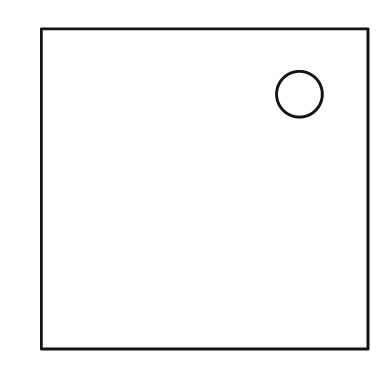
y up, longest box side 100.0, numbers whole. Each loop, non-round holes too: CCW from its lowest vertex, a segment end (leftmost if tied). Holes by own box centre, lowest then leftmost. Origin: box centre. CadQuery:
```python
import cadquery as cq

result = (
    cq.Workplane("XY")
    .moveTo(-50.0, -49.0)
    .lineTo(50.0, -49.0)
    .lineTo(50.0, 49.0)
    .lineTo(-50.0, 49.0)
    .close()
    .moveTo(29.0, 29.0)
    .circle(7.0)
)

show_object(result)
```